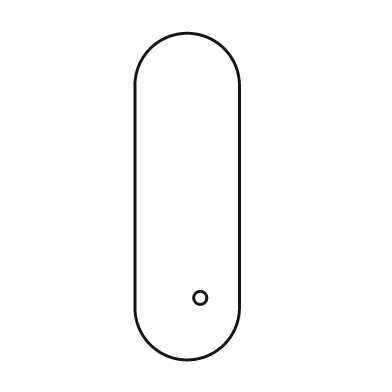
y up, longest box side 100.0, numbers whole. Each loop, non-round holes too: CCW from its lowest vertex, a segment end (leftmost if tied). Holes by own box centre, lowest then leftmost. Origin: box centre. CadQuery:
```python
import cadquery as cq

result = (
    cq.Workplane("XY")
    .moveTo(-16.0, -34.0)
    .threePointArc((0.0, -50.0), (16.0, -34.0))
    .lineTo(16.0, 34.0)
    .threePointArc((0.0, 50.0), (-16.0, 34.0))
    .close()
    .moveTo(4.0, -31.0)
    .circle(2.0)
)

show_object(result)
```